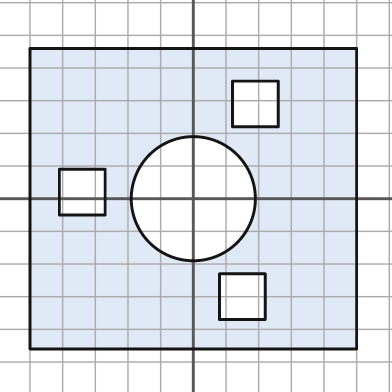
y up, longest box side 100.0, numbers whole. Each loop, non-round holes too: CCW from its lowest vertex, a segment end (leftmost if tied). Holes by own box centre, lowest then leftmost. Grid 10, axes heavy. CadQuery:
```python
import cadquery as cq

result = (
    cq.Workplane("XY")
    .moveTo(-50.0, -46.0)
    .lineTo(50.0, -46.0)
    .lineTo(50.0, 46.0)
    .lineTo(-50.0, 46.0)
    .close()
    .moveTo(8.0, -37.0)
    .lineTo(22.0, -37.0)
    .lineTo(22.0, -23.0)
    .lineTo(8.0, -23.0)
    .close()
    .moveTo(0.0, 0.0)
    .circle(19.0)
    .moveTo(-41.0, -5.0)
    .lineTo(-27.0, -5.0)
    .lineTo(-27.0, 9.0)
    .lineTo(-41.0, 9.0)
    .close()
    .moveTo(12.0, 22.0)
    .lineTo(26.0, 22.0)
    .lineTo(26.0, 36.0)
    .lineTo(12.0, 36.0)
    .close()
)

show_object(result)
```